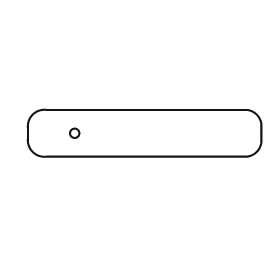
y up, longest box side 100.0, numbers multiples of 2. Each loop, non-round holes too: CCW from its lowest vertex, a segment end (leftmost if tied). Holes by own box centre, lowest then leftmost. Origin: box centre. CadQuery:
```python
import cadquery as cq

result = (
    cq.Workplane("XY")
    .moveTo(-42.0, -10.0)
    .lineTo(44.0, -10.0)
    .threePointArc((48.0, -8.0), (50.0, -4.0))
    .lineTo(50.0, 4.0)
    .threePointArc((48.0, 8.0), (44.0, 10.0))
    .lineTo(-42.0, 10.0)
    .threePointArc((-48.0, 8.0), (-50.0, 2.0))
    .lineTo(-50.0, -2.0)
    .threePointArc((-48.0, -8.0), (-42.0, -10.0))
    .close()
    .moveTo(-30.0, 0.0)
    .circle(2.0)
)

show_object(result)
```